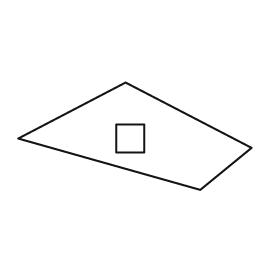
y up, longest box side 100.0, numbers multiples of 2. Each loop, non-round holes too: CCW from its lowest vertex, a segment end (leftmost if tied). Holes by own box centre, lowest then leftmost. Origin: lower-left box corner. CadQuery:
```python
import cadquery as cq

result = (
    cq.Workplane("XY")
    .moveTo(78.0, 0.0)
    .lineTo(100.0, 18.0)
    .lineTo(46.0, 46.0)
    .lineTo(0.0, 22.0)
    .close()
    .moveTo(42.0, 16.0)
    .lineTo(54.0, 16.0)
    .lineTo(54.0, 28.0)
    .lineTo(42.0, 28.0)
    .close()
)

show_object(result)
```